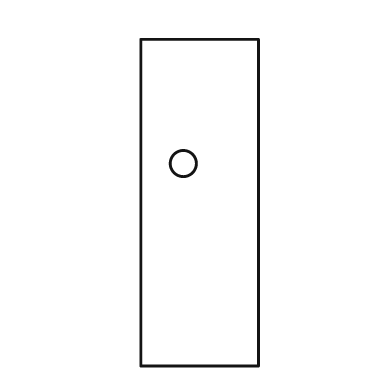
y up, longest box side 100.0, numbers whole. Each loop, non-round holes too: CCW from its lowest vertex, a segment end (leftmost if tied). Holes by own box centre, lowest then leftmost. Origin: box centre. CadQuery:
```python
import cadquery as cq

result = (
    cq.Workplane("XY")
    .moveTo(-18.0, -50.0)
    .lineTo(18.0, -50.0)
    .lineTo(18.0, 50.0)
    .lineTo(-18.0, 50.0)
    .close()
    .moveTo(-5.0, 12.0)
    .circle(4.0)
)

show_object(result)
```